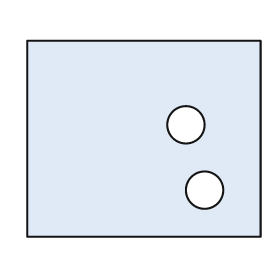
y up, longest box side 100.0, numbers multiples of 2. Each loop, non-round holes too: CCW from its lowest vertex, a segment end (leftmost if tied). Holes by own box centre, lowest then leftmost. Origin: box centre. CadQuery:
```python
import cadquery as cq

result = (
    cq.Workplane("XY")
    .moveTo(-50.0, -42.0)
    .lineTo(50.0, -42.0)
    .lineTo(50.0, 42.0)
    .lineTo(-50.0, 42.0)
    .close()
    .moveTo(26.0, -22.0)
    .circle(8.0)
    .moveTo(18.0, 6.0)
    .circle(8.0)
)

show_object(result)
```